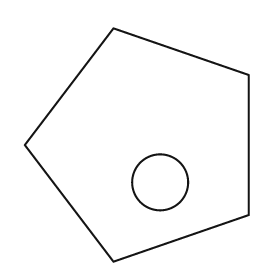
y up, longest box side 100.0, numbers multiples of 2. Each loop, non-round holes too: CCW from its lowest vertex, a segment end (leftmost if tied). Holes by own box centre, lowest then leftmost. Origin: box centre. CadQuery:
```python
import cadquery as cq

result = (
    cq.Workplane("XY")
    .moveTo(-10.0, -50.0)
    .lineTo(48.0, -30.0)
    .lineTo(48.0, 30.0)
    .lineTo(-10.0, 50.0)
    .lineTo(-48.0, 0.0)
    .close()
    .moveTo(10.0, -16.0)
    .circle(12.0)
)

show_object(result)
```